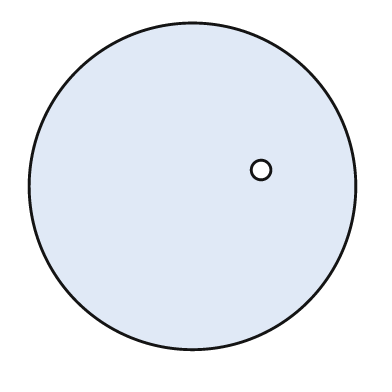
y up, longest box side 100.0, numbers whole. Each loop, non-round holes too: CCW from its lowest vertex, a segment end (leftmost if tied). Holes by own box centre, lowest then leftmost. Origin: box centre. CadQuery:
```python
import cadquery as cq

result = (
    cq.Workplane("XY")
    .moveTo(0.0, 0.0)
    .circle(50.0)
    .moveTo(21.0, 5.0)
    .circle(3.0)
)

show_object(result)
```